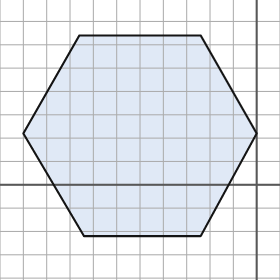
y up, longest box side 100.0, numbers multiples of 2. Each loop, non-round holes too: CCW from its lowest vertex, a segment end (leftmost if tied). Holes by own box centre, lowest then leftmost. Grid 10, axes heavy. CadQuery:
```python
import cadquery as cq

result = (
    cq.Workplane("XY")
    .moveTo(-74.0, -22.0)
    .lineTo(-24.0, -22.0)
    .lineTo(0.0, 22.0)
    .lineTo(-24.0, 64.0)
    .lineTo(-76.0, 64.0)
    .lineTo(-100.0, 22.0)
    .close()
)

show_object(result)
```